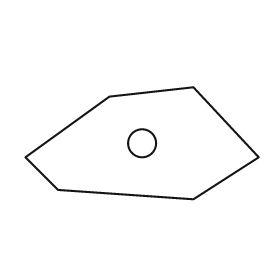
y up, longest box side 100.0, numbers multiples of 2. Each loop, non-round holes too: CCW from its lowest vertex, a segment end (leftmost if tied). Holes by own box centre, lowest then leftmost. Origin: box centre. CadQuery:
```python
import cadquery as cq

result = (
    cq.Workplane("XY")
    .moveTo(22.0, -24.0)
    .lineTo(50.0, -6.0)
    .lineTo(22.0, 24.0)
    .lineTo(-14.0, 20.0)
    .lineTo(-50.0, -6.0)
    .lineTo(-36.0, -20.0)
    .close()
    .moveTo(0.0, 0.0)
    .circle(6.0)
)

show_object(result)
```